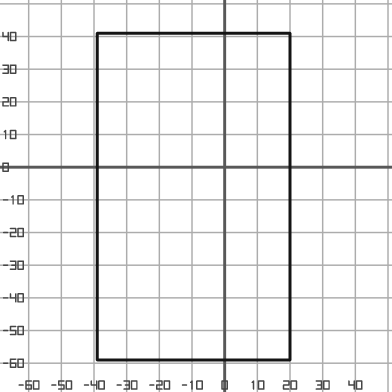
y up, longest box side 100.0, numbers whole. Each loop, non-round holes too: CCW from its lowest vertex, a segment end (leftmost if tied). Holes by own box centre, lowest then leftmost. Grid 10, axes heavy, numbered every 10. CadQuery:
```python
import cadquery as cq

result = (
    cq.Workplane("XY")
    .moveTo(-39.0, -59.0)
    .lineTo(20.0, -59.0)
    .lineTo(20.0, 41.0)
    .lineTo(-39.0, 41.0)
    .close()
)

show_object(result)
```